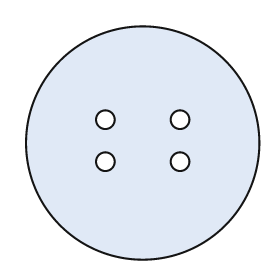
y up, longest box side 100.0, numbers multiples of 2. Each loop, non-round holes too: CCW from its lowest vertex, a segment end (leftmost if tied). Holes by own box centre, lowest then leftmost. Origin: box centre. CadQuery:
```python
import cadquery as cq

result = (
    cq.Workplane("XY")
    .moveTo(0.0, 0.0)
    .circle(50.0)
    .moveTo(-16.0, -8.0)
    .circle(4.0)
    .moveTo(16.0, -8.0)
    .circle(4.0)
    .moveTo(-16.0, 10.0)
    .circle(4.0)
    .moveTo(16.0, 10.0)
    .circle(4.0)
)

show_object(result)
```